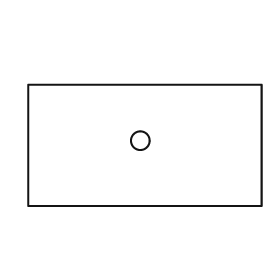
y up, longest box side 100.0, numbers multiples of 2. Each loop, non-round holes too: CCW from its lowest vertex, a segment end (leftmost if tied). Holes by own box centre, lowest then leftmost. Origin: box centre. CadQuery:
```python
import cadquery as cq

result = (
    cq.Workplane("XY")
    .moveTo(-50.0, -26.0)
    .lineTo(50.0, -26.0)
    .lineTo(50.0, 26.0)
    .lineTo(-50.0, 26.0)
    .close()
    .moveTo(-2.0, 2.0)
    .circle(4.0)
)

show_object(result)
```